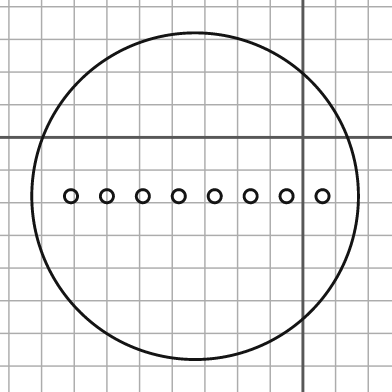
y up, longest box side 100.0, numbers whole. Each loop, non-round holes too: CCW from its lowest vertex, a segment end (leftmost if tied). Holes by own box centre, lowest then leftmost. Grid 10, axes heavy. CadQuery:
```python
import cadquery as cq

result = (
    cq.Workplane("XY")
    .moveTo(-33.0, -18.0)
    .circle(50.0)
    .moveTo(-71.0, -18.0)
    .circle(2.0)
    .moveTo(-60.0, -18.0)
    .circle(2.0)
    .moveTo(-49.0, -18.0)
    .circle(2.0)
    .moveTo(-38.0, -18.0)
    .circle(2.0)
    .moveTo(-27.0, -18.0)
    .circle(2.0)
    .moveTo(-16.0, -18.0)
    .circle(2.0)
    .moveTo(-5.0, -18.0)
    .circle(2.0)
    .moveTo(6.0, -18.0)
    .circle(2.0)
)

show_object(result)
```